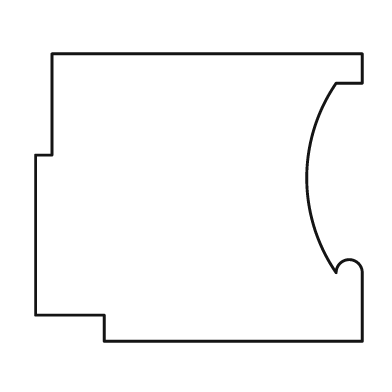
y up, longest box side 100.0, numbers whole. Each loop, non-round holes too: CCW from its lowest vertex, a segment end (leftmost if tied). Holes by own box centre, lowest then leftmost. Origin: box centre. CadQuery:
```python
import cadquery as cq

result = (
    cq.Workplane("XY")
    .moveTo(-29.0, -44.0)
    .lineTo(50.0, -44.0)
    .lineTo(50.0, -23.0)
    .threePointArc((46.0, -19.0), (42.0, -23.0))
    .threePointArc((33.0, 6.0), (42.0, 35.0))
    .lineTo(50.0, 35.0)
    .lineTo(50.0, 44.0)
    .lineTo(-45.0, 44.0)
    .lineTo(-45.0, 13.0)
    .lineTo(-50.0, 13.0)
    .lineTo(-50.0, -36.0)
    .lineTo(-29.0, -36.0)
    .close()
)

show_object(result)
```